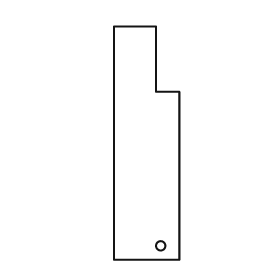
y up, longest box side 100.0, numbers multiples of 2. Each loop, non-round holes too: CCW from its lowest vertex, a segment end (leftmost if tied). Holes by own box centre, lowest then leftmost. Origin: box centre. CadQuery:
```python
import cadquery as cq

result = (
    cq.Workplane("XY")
    .moveTo(-14.0, -50.0)
    .lineTo(14.0, -50.0)
    .lineTo(14.0, 22.0)
    .lineTo(4.0, 22.0)
    .lineTo(4.0, 50.0)
    .lineTo(-14.0, 50.0)
    .close()
    .moveTo(6.0, -44.0)
    .circle(2.0)
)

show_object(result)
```